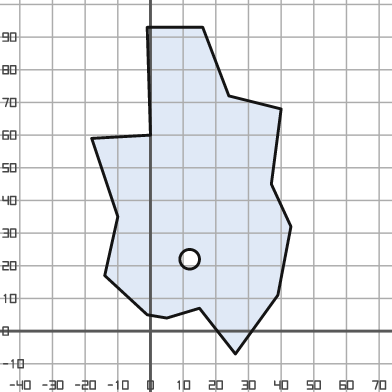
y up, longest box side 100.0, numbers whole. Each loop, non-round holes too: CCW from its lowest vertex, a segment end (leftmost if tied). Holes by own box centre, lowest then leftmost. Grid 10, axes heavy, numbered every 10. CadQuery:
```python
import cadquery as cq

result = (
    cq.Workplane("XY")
    .moveTo(26.0, -7.0)
    .lineTo(39.0, 11.0)
    .lineTo(43.0, 32.0)
    .lineTo(37.0, 45.0)
    .lineTo(40.0, 68.0)
    .lineTo(24.0, 72.0)
    .lineTo(16.0, 93.0)
    .lineTo(-1.0, 93.0)
    .lineTo(0.0, 60.0)
    .lineTo(-18.0, 59.0)
    .lineTo(-10.0, 35.0)
    .lineTo(-14.0, 17.0)
    .lineTo(-1.0, 5.0)
    .lineTo(5.0, 4.0)
    .lineTo(15.0, 7.0)
    .close()
    .moveTo(12.0, 22.0)
    .circle(3.0)
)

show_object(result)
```